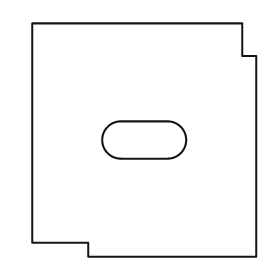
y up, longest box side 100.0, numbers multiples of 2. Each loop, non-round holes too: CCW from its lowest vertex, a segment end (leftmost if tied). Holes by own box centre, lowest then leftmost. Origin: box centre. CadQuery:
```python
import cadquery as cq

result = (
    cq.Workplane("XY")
    .moveTo(-24.0, -50.0)
    .lineTo(48.0, -50.0)
    .lineTo(48.0, 36.0)
    .lineTo(42.0, 36.0)
    .lineTo(42.0, 50.0)
    .lineTo(-48.0, 50.0)
    .lineTo(-48.0, -44.0)
    .lineTo(-24.0, -44.0)
    .close()
    .moveTo(-10.0, -8.0)
    .lineTo(10.0, -8.0)
    .threePointArc((18.0, 0.0), (10.0, 8.0))
    .lineTo(-10.0, 8.0)
    .threePointArc((-18.0, 0.0), (-10.0, -8.0))
    .close()
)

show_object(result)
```